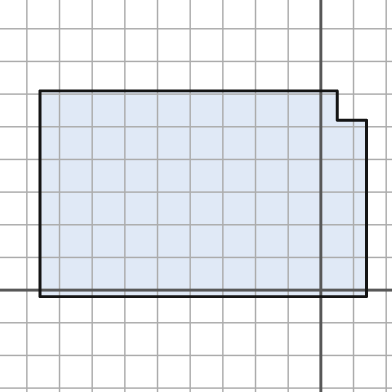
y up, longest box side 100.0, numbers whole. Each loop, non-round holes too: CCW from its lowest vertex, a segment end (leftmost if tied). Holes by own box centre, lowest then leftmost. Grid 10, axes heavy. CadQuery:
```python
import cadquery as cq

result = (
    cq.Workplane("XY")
    .moveTo(-86.0, -2.0)
    .lineTo(14.0, -2.0)
    .lineTo(14.0, 52.0)
    .lineTo(5.0, 52.0)
    .lineTo(5.0, 61.0)
    .lineTo(-86.0, 61.0)
    .close()
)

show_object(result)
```